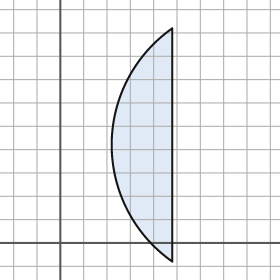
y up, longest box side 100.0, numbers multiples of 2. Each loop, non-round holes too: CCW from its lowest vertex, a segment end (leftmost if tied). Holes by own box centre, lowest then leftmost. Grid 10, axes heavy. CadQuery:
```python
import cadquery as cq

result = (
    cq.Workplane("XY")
    .moveTo(48.0, -8.0)
    .lineTo(48.0, 92.0)
    .threePointArc((22.0, 42.0), (48.0, -8.0))
    .close()
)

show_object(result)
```